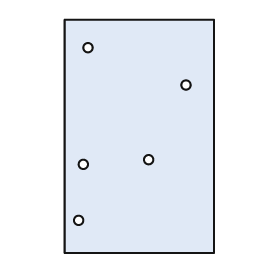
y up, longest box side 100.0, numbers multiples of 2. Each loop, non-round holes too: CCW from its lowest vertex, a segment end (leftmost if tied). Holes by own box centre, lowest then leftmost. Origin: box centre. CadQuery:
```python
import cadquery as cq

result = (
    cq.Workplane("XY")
    .moveTo(-32.0, -50.0)
    .lineTo(32.0, -50.0)
    .lineTo(32.0, 50.0)
    .lineTo(-32.0, 50.0)
    .close()
    .moveTo(-26.0, -36.0)
    .circle(2.0)
    .moveTo(-24.0, -12.0)
    .circle(2.0)
    .moveTo(4.0, -10.0)
    .circle(2.0)
    .moveTo(20.0, 22.0)
    .circle(2.0)
    .moveTo(-22.0, 38.0)
    .circle(2.0)
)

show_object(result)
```